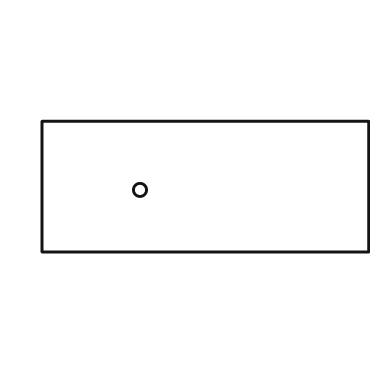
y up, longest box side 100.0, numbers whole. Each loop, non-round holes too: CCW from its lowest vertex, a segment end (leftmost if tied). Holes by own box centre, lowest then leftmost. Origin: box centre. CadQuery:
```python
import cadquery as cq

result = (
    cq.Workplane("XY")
    .moveTo(-50.0, -20.0)
    .lineTo(50.0, -20.0)
    .lineTo(50.0, 20.0)
    .lineTo(-50.0, 20.0)
    .close()
    .moveTo(-20.0, -1.0)
    .circle(2.0)
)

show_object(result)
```